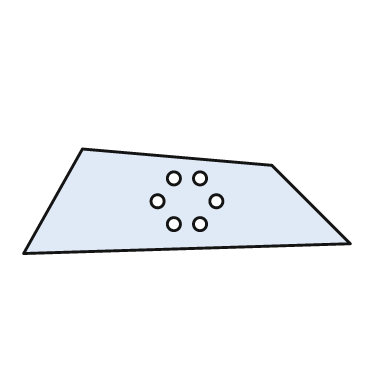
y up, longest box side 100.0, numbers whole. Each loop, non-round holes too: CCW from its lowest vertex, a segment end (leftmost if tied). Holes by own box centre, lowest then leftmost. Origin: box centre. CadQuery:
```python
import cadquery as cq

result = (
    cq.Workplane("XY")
    .moveTo(-50.0, -16.0)
    .lineTo(50.0, -13.0)
    .lineTo(26.0, 11.0)
    .lineTo(-32.0, 16.0)
    .close()
    .moveTo(-4.0, -7.0)
    .circle(2.0)
    .moveTo(4.0, -7.0)
    .circle(2.0)
    .moveTo(-9.0, 0.0)
    .circle(2.0)
    .moveTo(9.0, 0.0)
    .circle(2.0)
    .moveTo(-4.0, 7.0)
    .circle(2.0)
    .moveTo(4.0, 7.0)
    .circle(2.0)
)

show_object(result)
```